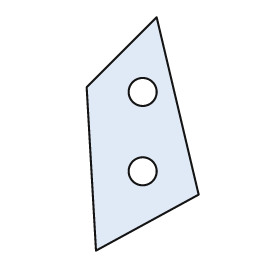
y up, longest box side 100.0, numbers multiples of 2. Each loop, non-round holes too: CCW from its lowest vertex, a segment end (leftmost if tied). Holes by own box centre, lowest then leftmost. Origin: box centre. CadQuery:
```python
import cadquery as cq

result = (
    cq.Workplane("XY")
    .moveTo(-20.0, -50.0)
    .lineTo(24.0, -26.0)
    .lineTo(6.0, 50.0)
    .lineTo(-24.0, 20.0)
    .close()
    .moveTo(0.0, -16.0)
    .circle(6.0)
    .moveTo(0.0, 18.0)
    .circle(6.0)
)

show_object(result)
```